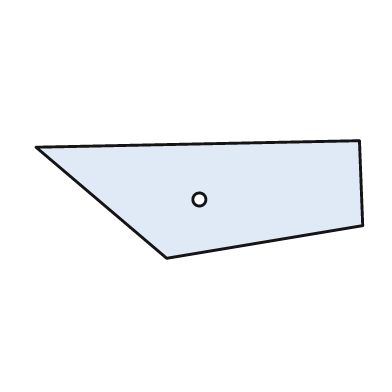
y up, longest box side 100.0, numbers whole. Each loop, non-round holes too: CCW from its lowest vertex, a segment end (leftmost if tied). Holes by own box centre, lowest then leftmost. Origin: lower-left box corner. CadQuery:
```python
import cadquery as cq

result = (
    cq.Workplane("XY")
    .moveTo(40.0, 0.0)
    .lineTo(100.0, 10.0)
    .lineTo(99.0, 36.0)
    .lineTo(0.0, 34.0)
    .close()
    .moveTo(50.0, 18.0)
    .circle(2.0)
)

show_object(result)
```